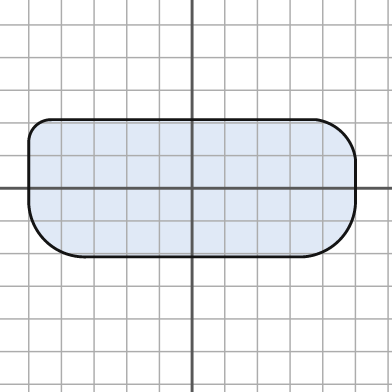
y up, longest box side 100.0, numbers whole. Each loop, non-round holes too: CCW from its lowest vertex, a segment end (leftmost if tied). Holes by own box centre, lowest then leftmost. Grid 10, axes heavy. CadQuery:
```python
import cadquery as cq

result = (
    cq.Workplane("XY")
    .moveTo(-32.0, -21.0)
    .lineTo(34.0, -21.0)
    .threePointArc((45.0, -16.0), (50.0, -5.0))
    .lineTo(50.0, 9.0)
    .threePointArc((46.0, 17.0), (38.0, 21.0))
    .lineTo(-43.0, 21.0)
    .threePointArc((-48.0, 19.0), (-50.0, 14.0))
    .lineTo(-50.0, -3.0)
    .threePointArc((-45.0, -16.0), (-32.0, -21.0))
    .close()
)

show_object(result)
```